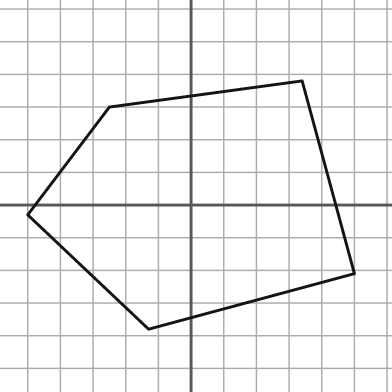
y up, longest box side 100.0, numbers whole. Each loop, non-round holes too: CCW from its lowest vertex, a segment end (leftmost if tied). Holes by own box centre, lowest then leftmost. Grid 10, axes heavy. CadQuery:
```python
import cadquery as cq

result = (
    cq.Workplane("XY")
    .moveTo(-13.0, -38.0)
    .lineTo(50.0, -21.0)
    .lineTo(34.0, 38.0)
    .lineTo(-25.0, 30.0)
    .lineTo(-50.0, -3.0)
    .close()
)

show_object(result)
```